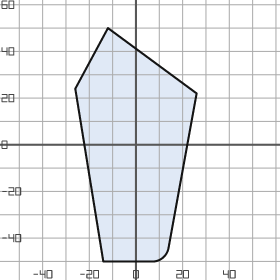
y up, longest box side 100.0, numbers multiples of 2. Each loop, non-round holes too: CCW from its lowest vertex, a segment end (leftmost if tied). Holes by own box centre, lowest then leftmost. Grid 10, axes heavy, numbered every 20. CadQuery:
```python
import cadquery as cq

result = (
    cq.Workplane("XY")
    .moveTo(-14.0, -50.0)
    .lineTo(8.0, -50.0)
    .threePointArc((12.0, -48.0), (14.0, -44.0))
    .lineTo(26.0, 22.0)
    .lineTo(-12.0, 50.0)
    .lineTo(-26.0, 24.0)
    .close()
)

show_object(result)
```